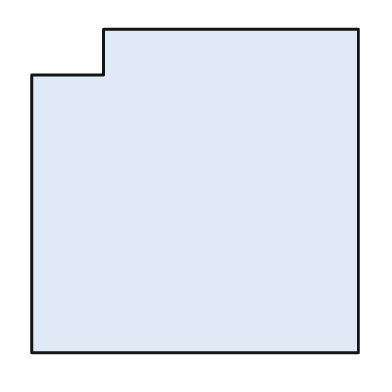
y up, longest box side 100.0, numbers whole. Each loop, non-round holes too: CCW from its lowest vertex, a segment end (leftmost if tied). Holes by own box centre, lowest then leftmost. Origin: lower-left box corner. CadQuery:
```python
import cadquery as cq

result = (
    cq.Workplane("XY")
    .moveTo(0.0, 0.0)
    .lineTo(100.0, 0.0)
    .lineTo(100.0, 99.0)
    .lineTo(22.0, 99.0)
    .lineTo(22.0, 85.0)
    .lineTo(0.0, 85.0)
    .close()
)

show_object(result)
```